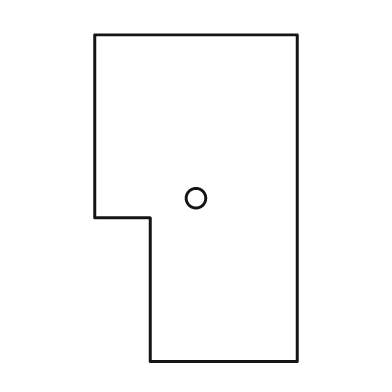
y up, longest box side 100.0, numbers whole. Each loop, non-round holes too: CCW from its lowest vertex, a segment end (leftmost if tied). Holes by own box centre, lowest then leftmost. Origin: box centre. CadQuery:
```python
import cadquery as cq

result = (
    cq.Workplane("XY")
    .moveTo(-14.0, -50.0)
    .lineTo(31.0, -50.0)
    .lineTo(31.0, 50.0)
    .lineTo(-31.0, 50.0)
    .lineTo(-31.0, -6.0)
    .lineTo(-14.0, -6.0)
    .close()
    .moveTo(0.0, 0.0)
    .circle(3.0)
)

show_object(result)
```